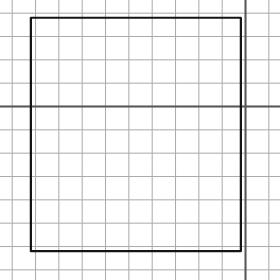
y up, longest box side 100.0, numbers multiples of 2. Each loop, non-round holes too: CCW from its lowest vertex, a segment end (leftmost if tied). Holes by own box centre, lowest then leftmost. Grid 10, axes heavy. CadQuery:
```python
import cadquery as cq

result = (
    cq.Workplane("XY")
    .moveTo(-92.0, -62.0)
    .lineTo(-2.0, -62.0)
    .lineTo(-2.0, 38.0)
    .lineTo(-92.0, 38.0)
    .close()
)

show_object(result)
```